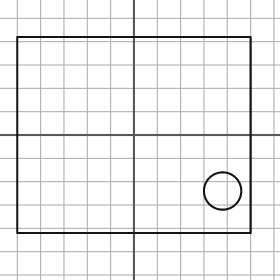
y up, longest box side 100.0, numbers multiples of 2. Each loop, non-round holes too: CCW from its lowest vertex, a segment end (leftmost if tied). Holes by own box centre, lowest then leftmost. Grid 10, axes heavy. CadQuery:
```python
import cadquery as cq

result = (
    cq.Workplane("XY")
    .moveTo(-50.0, -42.0)
    .lineTo(50.0, -42.0)
    .lineTo(50.0, 42.0)
    .lineTo(-50.0, 42.0)
    .close()
    .moveTo(38.0, -24.0)
    .circle(8.0)
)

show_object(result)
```